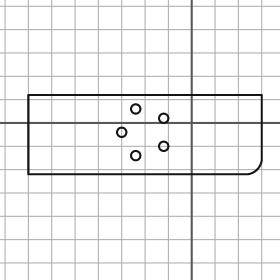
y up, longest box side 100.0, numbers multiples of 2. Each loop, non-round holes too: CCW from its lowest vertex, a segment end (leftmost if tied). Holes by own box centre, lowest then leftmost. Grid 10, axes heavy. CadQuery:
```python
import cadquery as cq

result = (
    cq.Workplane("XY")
    .moveTo(-70.0, -22.0)
    .lineTo(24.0, -22.0)
    .threePointArc((28.0, -20.0), (30.0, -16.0))
    .lineTo(30.0, 12.0)
    .lineTo(-70.0, 12.0)
    .close()
    .moveTo(-24.0, -14.0)
    .circle(2.0)
    .moveTo(-12.0, -10.0)
    .circle(2.0)
    .moveTo(-30.0, -4.0)
    .circle(2.0)
    .moveTo(-12.0, 2.0)
    .circle(2.0)
    .moveTo(-24.0, 6.0)
    .circle(2.0)
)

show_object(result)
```